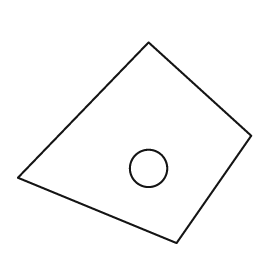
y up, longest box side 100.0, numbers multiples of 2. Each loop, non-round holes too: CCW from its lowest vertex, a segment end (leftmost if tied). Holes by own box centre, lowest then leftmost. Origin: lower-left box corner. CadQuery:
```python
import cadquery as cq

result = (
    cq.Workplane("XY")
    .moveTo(68.0, 0.0)
    .lineTo(100.0, 46.0)
    .lineTo(56.0, 86.0)
    .lineTo(0.0, 28.0)
    .close()
    .moveTo(56.0, 32.0)
    .circle(8.0)
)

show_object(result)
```